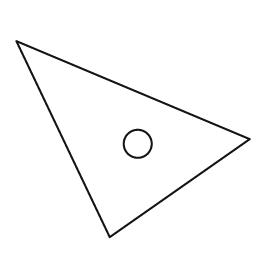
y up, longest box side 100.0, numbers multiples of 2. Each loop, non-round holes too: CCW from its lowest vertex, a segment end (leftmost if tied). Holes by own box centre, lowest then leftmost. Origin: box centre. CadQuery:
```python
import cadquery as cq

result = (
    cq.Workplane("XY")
    .moveTo(-10.0, -42.0)
    .lineTo(50.0, 0.0)
    .lineTo(-50.0, 42.0)
    .close()
    .moveTo(2.0, -2.0)
    .circle(6.0)
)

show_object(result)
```